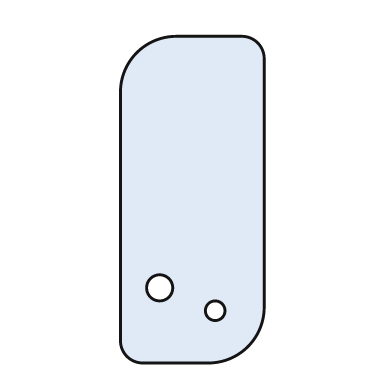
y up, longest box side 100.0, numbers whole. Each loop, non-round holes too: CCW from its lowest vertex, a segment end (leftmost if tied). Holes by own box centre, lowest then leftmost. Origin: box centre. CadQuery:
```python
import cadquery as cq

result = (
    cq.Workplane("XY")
    .moveTo(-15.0, -50.0)
    .lineTo(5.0, -50.0)
    .threePointArc((17.0, -45.0), (22.0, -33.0))
    .lineTo(22.0, 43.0)
    .threePointArc((20.0, 48.0), (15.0, 50.0))
    .lineTo(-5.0, 50.0)
    .threePointArc((-17.0, 45.0), (-22.0, 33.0))
    .lineTo(-22.0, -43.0)
    .threePointArc((-20.0, -48.0), (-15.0, -50.0))
    .close()
    .moveTo(7.0, -34.0)
    .circle(3.0)
    .moveTo(-10.0, -27.0)
    .circle(4.0)
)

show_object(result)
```